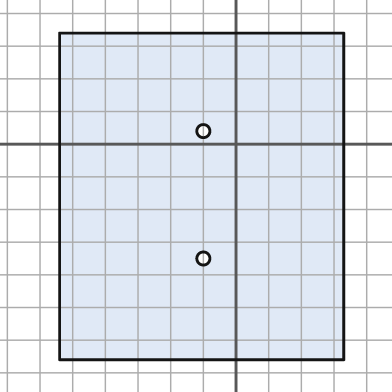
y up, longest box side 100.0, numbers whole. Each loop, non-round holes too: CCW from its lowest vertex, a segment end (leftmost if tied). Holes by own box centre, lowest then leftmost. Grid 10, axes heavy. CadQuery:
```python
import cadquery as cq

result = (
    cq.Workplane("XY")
    .moveTo(-54.0, -66.0)
    .lineTo(33.0, -66.0)
    .lineTo(33.0, 34.0)
    .lineTo(-54.0, 34.0)
    .close()
    .moveTo(-10.0, -35.0)
    .circle(2.0)
    .moveTo(-10.0, 4.0)
    .circle(2.0)
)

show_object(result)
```